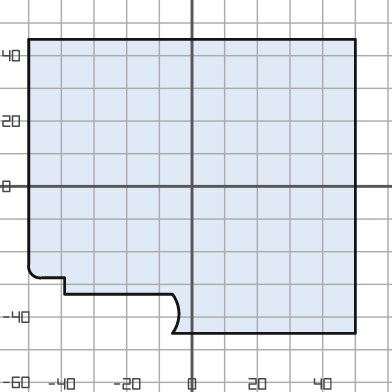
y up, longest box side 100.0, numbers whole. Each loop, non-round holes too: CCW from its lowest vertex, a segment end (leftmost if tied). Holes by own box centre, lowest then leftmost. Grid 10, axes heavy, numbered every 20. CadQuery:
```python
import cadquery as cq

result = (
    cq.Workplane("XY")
    .moveTo(-6.0, -45.0)
    .lineTo(50.0, -45.0)
    .lineTo(50.0, 45.0)
    .lineTo(-50.0, 45.0)
    .lineTo(-50.0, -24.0)
    .threePointArc((-49.0, -27.0), (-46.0, -28.0))
    .lineTo(-39.0, -28.0)
    .lineTo(-39.0, -33.0)
    .lineTo(-6.0, -33.0)
    .threePointArc((-4.0, -39.0), (-6.0, -45.0))
    .close()
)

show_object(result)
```